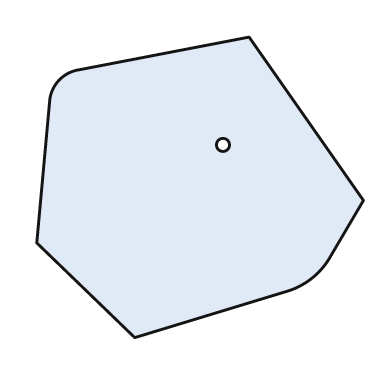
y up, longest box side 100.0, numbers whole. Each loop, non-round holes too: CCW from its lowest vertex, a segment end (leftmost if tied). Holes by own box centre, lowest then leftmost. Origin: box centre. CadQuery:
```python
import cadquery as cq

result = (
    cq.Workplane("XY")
    .moveTo(-20.0, -46.0)
    .lineTo(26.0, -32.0)
    .threePointArc((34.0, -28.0), (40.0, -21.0))
    .lineTo(50.0, -4.0)
    .lineTo(15.0, 46.0)
    .lineTo(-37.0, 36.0)
    .threePointArc((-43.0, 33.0), (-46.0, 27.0))
    .lineTo(-50.0, -17.0)
    .close()
    .moveTo(7.0, 13.0)
    .circle(2.0)
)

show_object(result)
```